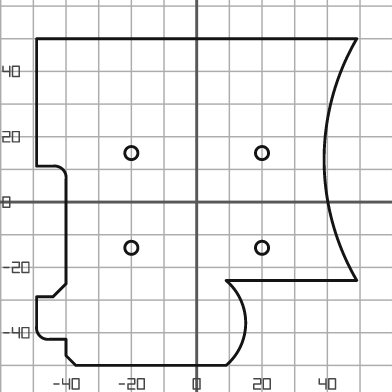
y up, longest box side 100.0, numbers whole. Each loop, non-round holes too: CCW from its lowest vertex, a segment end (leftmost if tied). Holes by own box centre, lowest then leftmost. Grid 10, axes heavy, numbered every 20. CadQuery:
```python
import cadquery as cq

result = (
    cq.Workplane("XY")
    .moveTo(-37.0, -50.0)
    .lineTo(9.0, -50.0)
    .threePointArc((15.0, -37.0), (9.0, -24.0))
    .lineTo(49.0, -24.0)
    .threePointArc((39.0, 13.0), (49.0, 50.0))
    .lineTo(-49.0, 50.0)
    .lineTo(-49.0, 11.0)
    .lineTo(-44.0, 11.0)
    .threePointArc((-41.0, 10.0), (-40.0, 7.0))
    .lineTo(-40.0, -25.0)
    .lineTo(-44.0, -29.0)
    .lineTo(-49.0, -29.0)
    .lineTo(-49.0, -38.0)
    .threePointArc((-48.0, -41.0), (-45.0, -42.0))
    .lineTo(-40.0, -42.0)
    .lineTo(-40.0, -47.0)
    .close()
    .moveTo(-20.0, -14.0)
    .circle(2.0)
    .moveTo(20.0, -14.0)
    .circle(2.0)
    .moveTo(-20.0, 15.0)
    .circle(2.0)
    .moveTo(20.0, 15.0)
    .circle(2.0)
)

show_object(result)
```